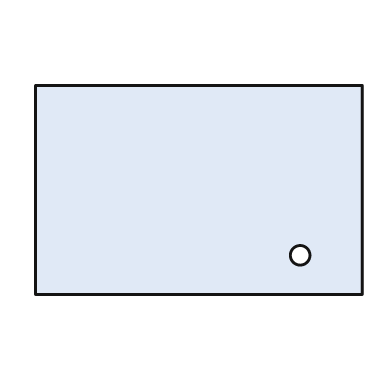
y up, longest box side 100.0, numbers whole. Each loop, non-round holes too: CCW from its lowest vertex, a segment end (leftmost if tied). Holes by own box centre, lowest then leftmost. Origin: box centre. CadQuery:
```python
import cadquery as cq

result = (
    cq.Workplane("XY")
    .moveTo(-50.0, -32.0)
    .lineTo(50.0, -32.0)
    .lineTo(50.0, 32.0)
    .lineTo(-50.0, 32.0)
    .close()
    .moveTo(31.0, -20.0)
    .circle(3.0)
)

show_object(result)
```